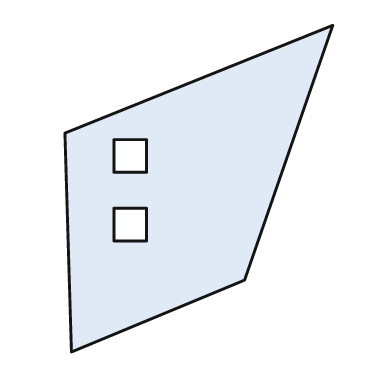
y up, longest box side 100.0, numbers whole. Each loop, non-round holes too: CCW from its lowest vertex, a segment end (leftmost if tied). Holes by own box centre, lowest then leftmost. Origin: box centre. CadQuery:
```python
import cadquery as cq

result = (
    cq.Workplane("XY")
    .moveTo(-39.0, -50.0)
    .lineTo(14.0, -28.0)
    .lineTo(41.0, 50.0)
    .lineTo(-41.0, 17.0)
    .close()
    .moveTo(-26.0, -16.0)
    .lineTo(-16.0, -16.0)
    .lineTo(-16.0, -6.0)
    .lineTo(-26.0, -6.0)
    .close()
    .moveTo(-26.0, 5.0)
    .lineTo(-16.0, 5.0)
    .lineTo(-16.0, 15.0)
    .lineTo(-26.0, 15.0)
    .close()
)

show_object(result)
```